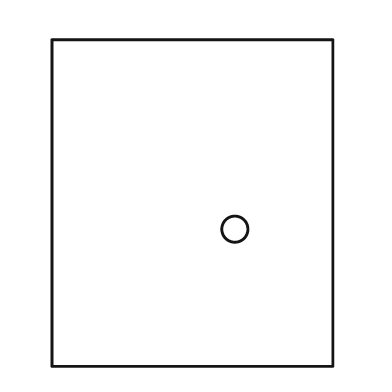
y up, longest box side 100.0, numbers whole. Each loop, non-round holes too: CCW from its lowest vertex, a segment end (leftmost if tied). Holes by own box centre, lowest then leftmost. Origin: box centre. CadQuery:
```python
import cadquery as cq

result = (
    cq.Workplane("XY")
    .moveTo(-43.0, -50.0)
    .lineTo(43.0, -50.0)
    .lineTo(43.0, 50.0)
    .lineTo(-43.0, 50.0)
    .close()
    .moveTo(13.0, -8.0)
    .circle(4.0)
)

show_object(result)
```